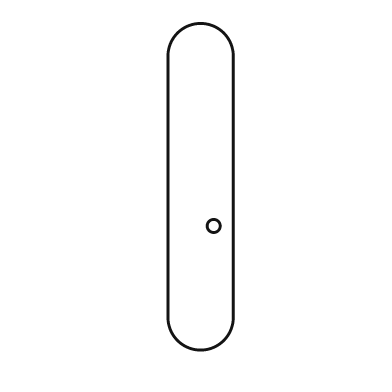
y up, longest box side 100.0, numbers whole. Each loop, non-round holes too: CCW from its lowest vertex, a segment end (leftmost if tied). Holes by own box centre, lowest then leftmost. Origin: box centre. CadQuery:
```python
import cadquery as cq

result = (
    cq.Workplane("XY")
    .moveTo(-10.0, -40.0)
    .threePointArc((0.0, -50.0), (10.0, -40.0))
    .lineTo(10.0, 40.0)
    .threePointArc((0.0, 50.0), (-10.0, 40.0))
    .close()
    .moveTo(4.0, -12.0)
    .circle(2.0)
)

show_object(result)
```